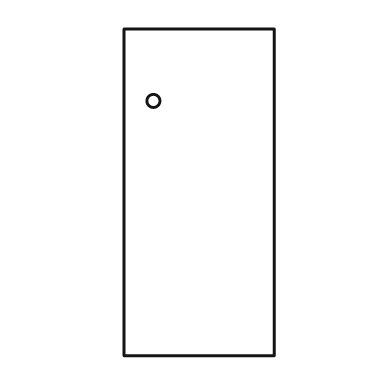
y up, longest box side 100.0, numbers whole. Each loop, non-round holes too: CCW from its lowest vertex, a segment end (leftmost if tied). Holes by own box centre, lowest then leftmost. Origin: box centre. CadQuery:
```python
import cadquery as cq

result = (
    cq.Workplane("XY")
    .moveTo(-23.0, -50.0)
    .lineTo(23.0, -50.0)
    .lineTo(23.0, 50.0)
    .lineTo(-23.0, 50.0)
    .close()
    .moveTo(-14.0, 28.0)
    .circle(2.0)
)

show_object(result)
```